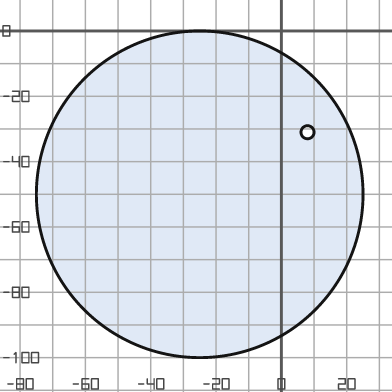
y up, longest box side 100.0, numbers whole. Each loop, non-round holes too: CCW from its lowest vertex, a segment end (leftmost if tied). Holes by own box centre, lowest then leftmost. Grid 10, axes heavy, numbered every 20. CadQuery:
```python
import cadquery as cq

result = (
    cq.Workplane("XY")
    .moveTo(-25.0, -50.0)
    .circle(50.0)
    .moveTo(8.0, -31.0)
    .circle(2.0)
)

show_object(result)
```